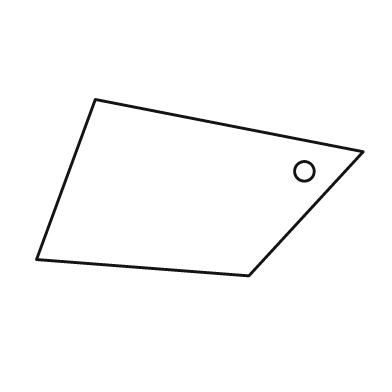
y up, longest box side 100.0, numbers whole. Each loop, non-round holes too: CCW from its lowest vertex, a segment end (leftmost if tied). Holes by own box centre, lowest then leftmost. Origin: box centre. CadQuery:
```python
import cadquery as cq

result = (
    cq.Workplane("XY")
    .moveTo(15.0, -27.0)
    .lineTo(50.0, 11.0)
    .lineTo(-32.0, 27.0)
    .lineTo(-50.0, -22.0)
    .close()
    .moveTo(32.0, 5.0)
    .circle(3.0)
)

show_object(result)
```